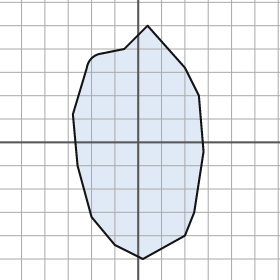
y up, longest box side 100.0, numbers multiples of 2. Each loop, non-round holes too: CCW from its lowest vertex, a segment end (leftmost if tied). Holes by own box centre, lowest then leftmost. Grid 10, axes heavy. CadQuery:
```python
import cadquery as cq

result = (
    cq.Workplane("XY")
    .moveTo(2.0, -50.0)
    .lineTo(20.0, -40.0)
    .lineTo(24.0, -30.0)
    .lineTo(28.0, -4.0)
    .lineTo(26.0, 20.0)
    .lineTo(20.0, 32.0)
    .lineTo(4.0, 50.0)
    .lineTo(-6.0, 40.0)
    .lineTo(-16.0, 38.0)
    .threePointArc((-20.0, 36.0), (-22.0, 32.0))
    .lineTo(-28.0, 12.0)
    .lineTo(-26.0, -10.0)
    .lineTo(-20.0, -32.0)
    .lineTo(-10.0, -44.0)
    .close()
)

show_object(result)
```